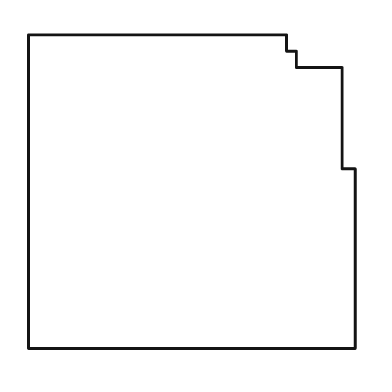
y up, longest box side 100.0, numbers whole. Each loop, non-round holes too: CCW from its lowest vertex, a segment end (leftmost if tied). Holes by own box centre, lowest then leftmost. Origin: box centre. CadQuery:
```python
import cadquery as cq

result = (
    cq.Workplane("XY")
    .moveTo(-50.0, -48.0)
    .lineTo(50.0, -48.0)
    .lineTo(50.0, 7.0)
    .lineTo(46.0, 7.0)
    .lineTo(46.0, 38.0)
    .lineTo(32.0, 38.0)
    .lineTo(32.0, 43.0)
    .lineTo(29.0, 43.0)
    .lineTo(29.0, 48.0)
    .lineTo(-50.0, 48.0)
    .close()
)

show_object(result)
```